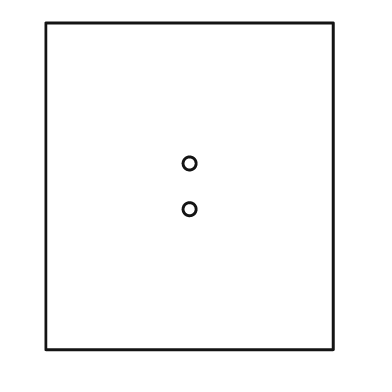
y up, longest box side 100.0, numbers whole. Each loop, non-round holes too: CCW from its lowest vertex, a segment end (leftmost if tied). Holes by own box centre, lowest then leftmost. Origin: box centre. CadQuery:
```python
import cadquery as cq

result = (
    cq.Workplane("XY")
    .moveTo(-44.0, -50.0)
    .lineTo(44.0, -50.0)
    .lineTo(44.0, 50.0)
    .lineTo(-44.0, 50.0)
    .close()
    .moveTo(0.0, -7.0)
    .circle(2.0)
    .moveTo(0.0, 7.0)
    .circle(2.0)
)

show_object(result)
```